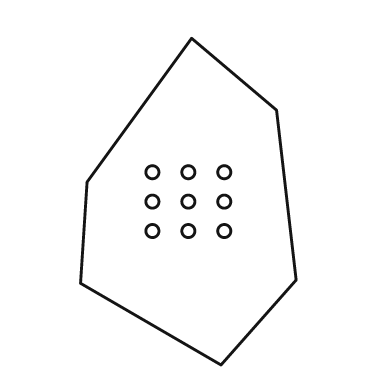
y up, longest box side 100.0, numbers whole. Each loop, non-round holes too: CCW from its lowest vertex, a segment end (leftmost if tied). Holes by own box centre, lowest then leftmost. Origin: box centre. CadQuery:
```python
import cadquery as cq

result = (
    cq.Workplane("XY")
    .moveTo(10.0, -50.0)
    .lineTo(33.0, -24.0)
    .lineTo(27.0, 28.0)
    .lineTo(1.0, 50.0)
    .lineTo(-31.0, 6.0)
    .lineTo(-33.0, -25.0)
    .close()
    .moveTo(-11.0, -9.0)
    .circle(2.0)
    .moveTo(0.0, -9.0)
    .circle(2.0)
    .moveTo(11.0, -9.0)
    .circle(2.0)
    .moveTo(-11.0, 0.0)
    .circle(2.0)
    .moveTo(0.0, 0.0)
    .circle(2.0)
    .moveTo(11.0, 0.0)
    .circle(2.0)
    .moveTo(-11.0, 9.0)
    .circle(2.0)
    .moveTo(0.0, 9.0)
    .circle(2.0)
    .moveTo(11.0, 9.0)
    .circle(2.0)
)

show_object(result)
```